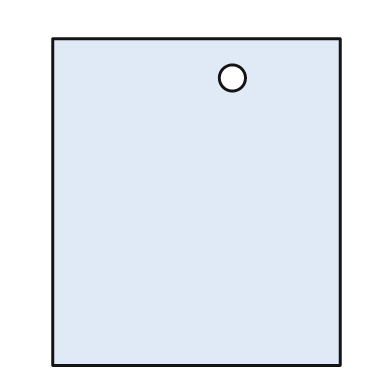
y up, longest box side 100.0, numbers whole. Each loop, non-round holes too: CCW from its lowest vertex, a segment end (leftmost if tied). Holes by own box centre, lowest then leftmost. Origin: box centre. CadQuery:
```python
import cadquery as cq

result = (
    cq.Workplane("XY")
    .moveTo(-44.0, -50.0)
    .lineTo(44.0, -50.0)
    .lineTo(44.0, 50.0)
    .lineTo(-44.0, 50.0)
    .close()
    .moveTo(11.0, 38.0)
    .circle(4.0)
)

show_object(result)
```